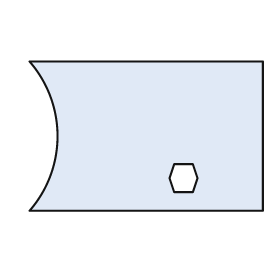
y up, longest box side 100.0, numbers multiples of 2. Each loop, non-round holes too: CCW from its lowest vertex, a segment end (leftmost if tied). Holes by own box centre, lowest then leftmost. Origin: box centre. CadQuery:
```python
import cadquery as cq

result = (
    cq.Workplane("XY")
    .moveTo(-50.0, -32.0)
    .lineTo(50.0, -32.0)
    .lineTo(50.0, 32.0)
    .lineTo(-50.0, 32.0)
    .threePointArc((-38.0, 0.0), (-50.0, -32.0))
    .close()
    .moveTo(12.0, -24.0)
    .lineTo(20.0, -24.0)
    .lineTo(22.0, -18.0)
    .lineTo(20.0, -12.0)
    .lineTo(12.0, -12.0)
    .lineTo(10.0, -18.0)
    .close()
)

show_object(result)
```